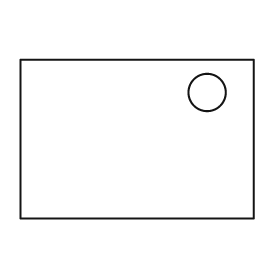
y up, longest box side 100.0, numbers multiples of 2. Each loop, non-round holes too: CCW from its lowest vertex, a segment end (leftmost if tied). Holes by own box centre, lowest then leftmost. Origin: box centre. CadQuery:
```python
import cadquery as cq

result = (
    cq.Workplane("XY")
    .moveTo(-50.0, -34.0)
    .lineTo(50.0, -34.0)
    .lineTo(50.0, 34.0)
    .lineTo(-50.0, 34.0)
    .close()
    .moveTo(30.0, 20.0)
    .circle(8.0)
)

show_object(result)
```